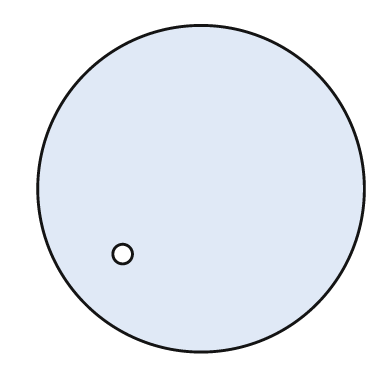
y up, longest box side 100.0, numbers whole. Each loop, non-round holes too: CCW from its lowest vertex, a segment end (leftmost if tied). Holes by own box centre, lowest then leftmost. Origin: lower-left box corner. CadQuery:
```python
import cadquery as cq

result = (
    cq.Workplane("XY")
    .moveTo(50.0, 50.0)
    .circle(50.0)
    .moveTo(26.0, 30.0)
    .circle(3.0)
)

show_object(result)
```